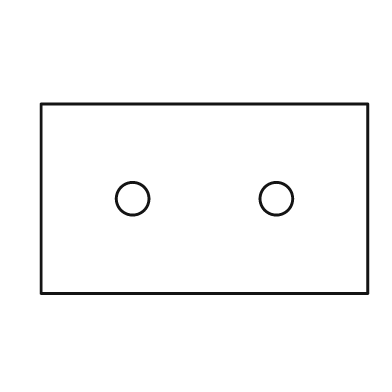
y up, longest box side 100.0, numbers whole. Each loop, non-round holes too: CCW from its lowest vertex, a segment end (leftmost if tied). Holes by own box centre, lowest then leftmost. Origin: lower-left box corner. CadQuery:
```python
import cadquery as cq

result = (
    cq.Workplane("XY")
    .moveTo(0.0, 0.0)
    .lineTo(100.0, 0.0)
    .lineTo(100.0, 58.0)
    .lineTo(0.0, 58.0)
    .close()
    .moveTo(28.0, 29.0)
    .circle(5.0)
    .moveTo(72.0, 29.0)
    .circle(5.0)
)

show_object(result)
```